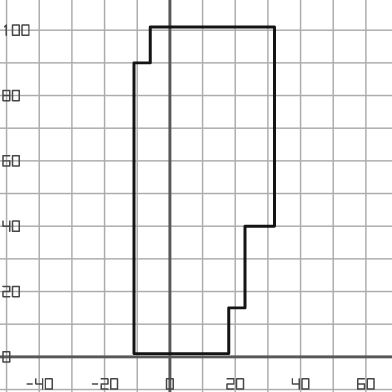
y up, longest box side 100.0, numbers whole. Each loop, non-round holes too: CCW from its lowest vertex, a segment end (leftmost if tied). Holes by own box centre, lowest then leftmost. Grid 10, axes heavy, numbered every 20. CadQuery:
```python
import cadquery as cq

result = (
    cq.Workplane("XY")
    .moveTo(-11.0, 1.0)
    .lineTo(18.0, 1.0)
    .lineTo(18.0, 15.0)
    .lineTo(23.0, 15.0)
    .lineTo(23.0, 40.0)
    .lineTo(32.0, 40.0)
    .lineTo(32.0, 101.0)
    .lineTo(-6.0, 101.0)
    .lineTo(-6.0, 90.0)
    .lineTo(-11.0, 90.0)
    .close()
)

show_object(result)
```